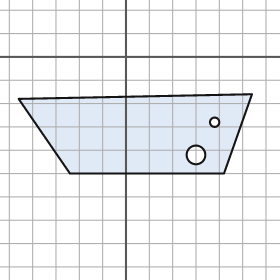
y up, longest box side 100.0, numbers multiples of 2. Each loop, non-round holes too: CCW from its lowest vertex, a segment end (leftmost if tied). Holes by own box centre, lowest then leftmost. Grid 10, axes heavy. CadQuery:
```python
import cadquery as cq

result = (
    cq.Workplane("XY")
    .moveTo(-24.0, -50.0)
    .lineTo(42.0, -50.0)
    .lineTo(54.0, -16.0)
    .lineTo(-46.0, -18.0)
    .close()
    .moveTo(30.0, -42.0)
    .circle(4.0)
    .moveTo(38.0, -28.0)
    .circle(2.0)
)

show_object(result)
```